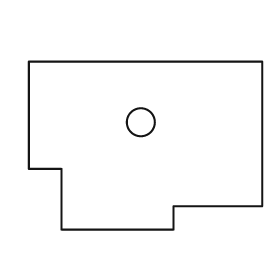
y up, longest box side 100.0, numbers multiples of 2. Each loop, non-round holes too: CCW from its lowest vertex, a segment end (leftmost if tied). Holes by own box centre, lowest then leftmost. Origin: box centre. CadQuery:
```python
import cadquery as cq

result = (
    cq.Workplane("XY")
    .moveTo(-36.0, -36.0)
    .lineTo(12.0, -36.0)
    .lineTo(12.0, -26.0)
    .lineTo(50.0, -26.0)
    .lineTo(50.0, 36.0)
    .lineTo(-50.0, 36.0)
    .lineTo(-50.0, -10.0)
    .lineTo(-36.0, -10.0)
    .close()
    .moveTo(-2.0, 10.0)
    .circle(6.0)
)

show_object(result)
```